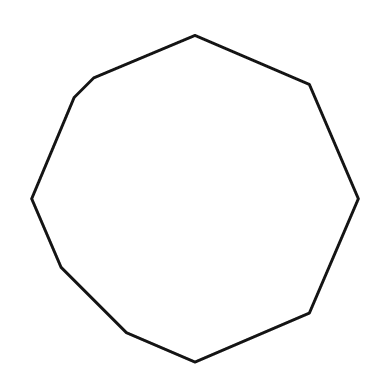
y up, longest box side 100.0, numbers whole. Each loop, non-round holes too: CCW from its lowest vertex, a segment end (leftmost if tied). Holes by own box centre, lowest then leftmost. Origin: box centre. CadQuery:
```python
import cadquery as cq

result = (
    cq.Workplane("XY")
    .moveTo(0.0, -50.0)
    .lineTo(35.0, -35.0)
    .lineTo(50.0, 0.0)
    .lineTo(35.0, 35.0)
    .lineTo(0.0, 50.0)
    .lineTo(-31.0, 37.0)
    .lineTo(-37.0, 31.0)
    .lineTo(-50.0, 0.0)
    .lineTo(-41.0, -21.0)
    .lineTo(-21.0, -41.0)
    .close()
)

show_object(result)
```